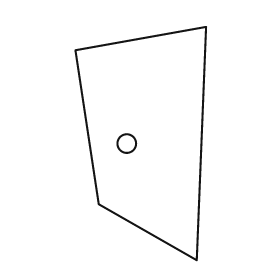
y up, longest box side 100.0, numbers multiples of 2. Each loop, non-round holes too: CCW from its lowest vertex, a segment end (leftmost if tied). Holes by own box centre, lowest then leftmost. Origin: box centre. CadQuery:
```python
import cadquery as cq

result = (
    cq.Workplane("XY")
    .moveTo(24.0, -50.0)
    .lineTo(28.0, 50.0)
    .lineTo(-28.0, 40.0)
    .lineTo(-18.0, -26.0)
    .close()
    .moveTo(-6.0, 0.0)
    .circle(4.0)
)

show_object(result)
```